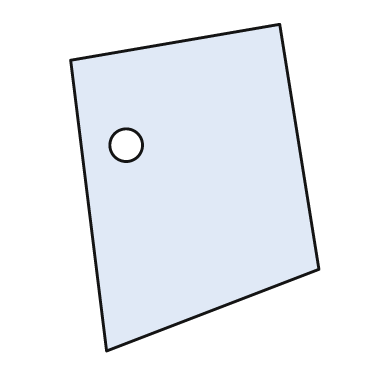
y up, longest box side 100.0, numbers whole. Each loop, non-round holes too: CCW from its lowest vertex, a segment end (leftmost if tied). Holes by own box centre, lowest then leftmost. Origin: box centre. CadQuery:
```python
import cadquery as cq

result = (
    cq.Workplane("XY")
    .moveTo(-27.0, -50.0)
    .lineTo(38.0, -25.0)
    .lineTo(26.0, 50.0)
    .lineTo(-38.0, 39.0)
    .close()
    .moveTo(-21.0, 13.0)
    .circle(5.0)
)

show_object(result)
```